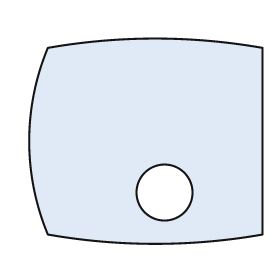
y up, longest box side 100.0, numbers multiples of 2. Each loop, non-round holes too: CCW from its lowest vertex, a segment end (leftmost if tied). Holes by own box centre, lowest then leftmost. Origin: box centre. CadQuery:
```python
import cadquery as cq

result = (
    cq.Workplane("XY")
    .moveTo(-42.0, -40.0)
    .threePointArc((4.0, -44.0), (50.0, -40.0))
    .lineTo(50.0, 40.0)
    .threePointArc((4.0, 44.0), (-42.0, 40.0))
    .threePointArc((-50.0, 0.0), (-42.0, -40.0))
    .close()
    .moveTo(8.0, -22.0)
    .circle(12.0)
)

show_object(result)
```